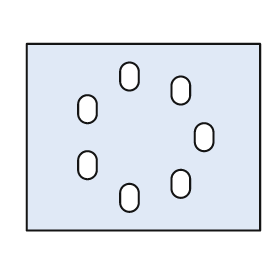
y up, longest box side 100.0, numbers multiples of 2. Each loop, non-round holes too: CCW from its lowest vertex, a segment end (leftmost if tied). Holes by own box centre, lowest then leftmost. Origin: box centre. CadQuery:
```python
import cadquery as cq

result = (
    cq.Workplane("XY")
    .moveTo(-50.0, -40.0)
    .lineTo(50.0, -40.0)
    .lineTo(50.0, 40.0)
    .lineTo(-50.0, 40.0)
    .close()
    .moveTo(-10.0, -28.0)
    .threePointArc((-6.0, -32.0), (-2.0, -28.0))
    .lineTo(-2.0, -24.0)
    .threePointArc((-6.0, -20.0), (-10.0, -24.0))
    .close()
    .moveTo(12.0, -22.0)
    .threePointArc((16.0, -26.0), (20.0, -22.0))
    .lineTo(20.0, -18.0)
    .threePointArc((16.0, -14.0), (12.0, -18.0))
    .close()
    .moveTo(-28.0, -14.0)
    .threePointArc((-24.0, -18.0), (-20.0, -14.0))
    .lineTo(-20.0, -10.0)
    .threePointArc((-24.0, -6.0), (-28.0, -10.0))
    .close()
    .moveTo(22.0, -2.0)
    .threePointArc((26.0, -6.0), (30.0, -2.0))
    .lineTo(30.0, 2.0)
    .threePointArc((26.0, 6.0), (22.0, 2.0))
    .close()
    .moveTo(-28.0, 10.0)
    .threePointArc((-24.0, 6.0), (-20.0, 10.0))
    .lineTo(-20.0, 14.0)
    .threePointArc((-24.0, 18.0), (-28.0, 14.0))
    .close()
    .moveTo(12.0, 18.0)
    .threePointArc((16.0, 14.0), (20.0, 18.0))
    .lineTo(20.0, 22.0)
    .threePointArc((16.0, 26.0), (12.0, 22.0))
    .close()
    .moveTo(-10.0, 24.0)
    .threePointArc((-6.0, 20.0), (-2.0, 24.0))
    .lineTo(-2.0, 28.0)
    .threePointArc((-6.0, 32.0), (-10.0, 28.0))
    .close()
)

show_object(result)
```